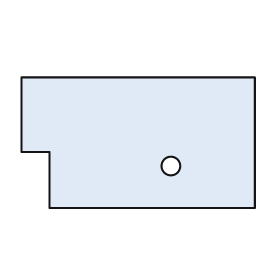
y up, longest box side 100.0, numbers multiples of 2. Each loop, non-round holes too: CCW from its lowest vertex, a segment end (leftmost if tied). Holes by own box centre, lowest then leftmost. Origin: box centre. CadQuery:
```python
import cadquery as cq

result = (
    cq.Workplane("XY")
    .moveTo(-38.0, -28.0)
    .lineTo(50.0, -28.0)
    .lineTo(50.0, 28.0)
    .lineTo(-50.0, 28.0)
    .lineTo(-50.0, -4.0)
    .lineTo(-38.0, -4.0)
    .close()
    .moveTo(14.0, -10.0)
    .circle(4.0)
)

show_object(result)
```